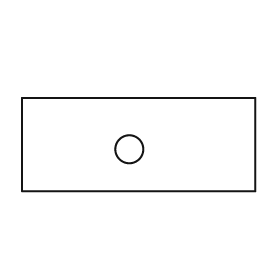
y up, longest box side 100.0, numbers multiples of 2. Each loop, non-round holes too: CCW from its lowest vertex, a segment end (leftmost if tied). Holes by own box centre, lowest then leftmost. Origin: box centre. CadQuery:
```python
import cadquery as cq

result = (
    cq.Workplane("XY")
    .moveTo(-50.0, -20.0)
    .lineTo(50.0, -20.0)
    .lineTo(50.0, 20.0)
    .lineTo(-50.0, 20.0)
    .close()
    .moveTo(-4.0, -2.0)
    .circle(6.0)
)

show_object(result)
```